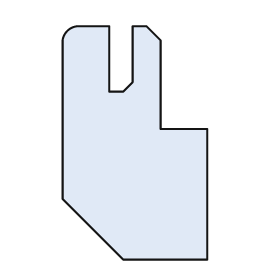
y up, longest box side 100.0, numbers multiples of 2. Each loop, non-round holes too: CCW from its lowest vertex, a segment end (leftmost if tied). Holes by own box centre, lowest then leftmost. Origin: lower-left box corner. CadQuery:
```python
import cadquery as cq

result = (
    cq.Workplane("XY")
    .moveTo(26.0, 0.0)
    .lineTo(62.0, 0.0)
    .lineTo(62.0, 56.0)
    .lineTo(42.0, 56.0)
    .lineTo(42.0, 94.0)
    .lineTo(36.0, 100.0)
    .lineTo(30.0, 100.0)
    .lineTo(30.0, 76.0)
    .lineTo(26.0, 72.0)
    .lineTo(20.0, 72.0)
    .lineTo(20.0, 100.0)
    .lineTo(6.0, 100.0)
    .threePointArc((2.0, 98.0), (0.0, 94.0))
    .lineTo(0.0, 26.0)
    .close()
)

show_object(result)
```